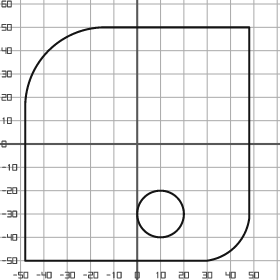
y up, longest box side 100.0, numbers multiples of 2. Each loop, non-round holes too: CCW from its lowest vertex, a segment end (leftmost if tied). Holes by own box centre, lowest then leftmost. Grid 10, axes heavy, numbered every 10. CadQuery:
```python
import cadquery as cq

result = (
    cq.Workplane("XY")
    .moveTo(-48.0, -50.0)
    .lineTo(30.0, -50.0)
    .threePointArc((42.0, -44.0), (48.0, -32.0))
    .lineTo(48.0, 50.0)
    .lineTo(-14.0, 50.0)
    .threePointArc((-38.0, 40.0), (-48.0, 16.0))
    .close()
    .moveTo(10.0, -30.0)
    .circle(10.0)
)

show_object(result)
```